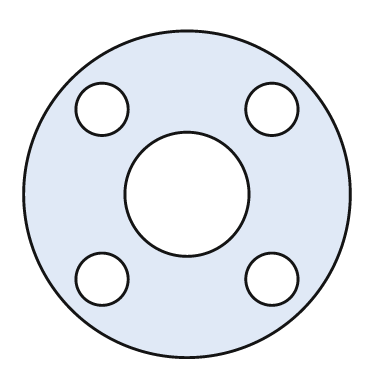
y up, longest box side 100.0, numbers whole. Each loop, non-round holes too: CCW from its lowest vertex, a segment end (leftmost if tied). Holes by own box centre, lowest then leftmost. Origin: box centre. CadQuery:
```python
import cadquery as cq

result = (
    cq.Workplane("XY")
    .moveTo(0.0, 0.0)
    .circle(50.0)
    .moveTo(-26.0, -26.0)
    .circle(8.0)
    .moveTo(26.0, -26.0)
    .circle(8.0)
    .moveTo(0.0, 0.0)
    .circle(19.0)
    .moveTo(-26.0, 26.0)
    .circle(8.0)
    .moveTo(26.0, 26.0)
    .circle(8.0)
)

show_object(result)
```